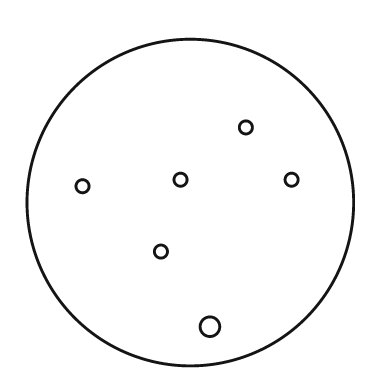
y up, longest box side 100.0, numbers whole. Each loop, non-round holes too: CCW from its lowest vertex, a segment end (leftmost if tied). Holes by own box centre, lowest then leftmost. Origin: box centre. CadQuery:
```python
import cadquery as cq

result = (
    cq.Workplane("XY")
    .moveTo(0.0, 0.0)
    .circle(50.0)
    .moveTo(6.0, -38.0)
    .circle(3.0)
    .moveTo(-9.0, -15.0)
    .circle(2.0)
    .moveTo(-33.0, 5.0)
    .circle(2.0)
    .moveTo(-3.0, 7.0)
    .circle(2.0)
    .moveTo(31.0, 7.0)
    .circle(2.0)
    .moveTo(17.0, 23.0)
    .circle(2.0)
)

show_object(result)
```